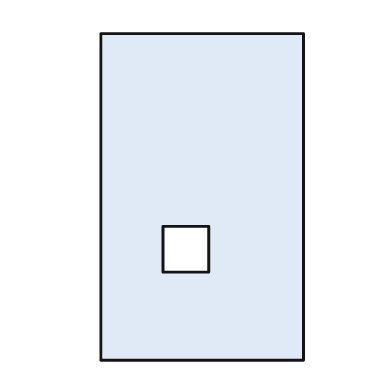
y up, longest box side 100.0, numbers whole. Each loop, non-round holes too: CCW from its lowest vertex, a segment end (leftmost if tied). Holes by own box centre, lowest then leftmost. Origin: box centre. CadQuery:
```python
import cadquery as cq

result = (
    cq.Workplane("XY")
    .moveTo(-31.0, -50.0)
    .lineTo(31.0, -50.0)
    .lineTo(31.0, 50.0)
    .lineTo(-31.0, 50.0)
    .close()
    .moveTo(-12.0, -23.0)
    .lineTo(2.0, -23.0)
    .lineTo(2.0, -9.0)
    .lineTo(-12.0, -9.0)
    .close()
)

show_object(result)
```